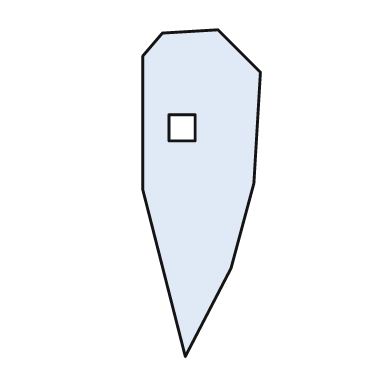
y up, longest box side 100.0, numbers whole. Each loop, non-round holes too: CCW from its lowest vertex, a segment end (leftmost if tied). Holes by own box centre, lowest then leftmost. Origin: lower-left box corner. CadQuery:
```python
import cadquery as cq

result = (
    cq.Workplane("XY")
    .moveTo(13.0, 0.0)
    .lineTo(27.0, 27.0)
    .lineTo(34.0, 53.0)
    .lineTo(36.0, 87.0)
    .lineTo(23.0, 100.0)
    .lineTo(6.0, 99.0)
    .lineTo(0.0, 92.0)
    .lineTo(0.0, 51.0)
    .close()
    .moveTo(8.0, 66.0)
    .lineTo(16.0, 66.0)
    .lineTo(16.0, 74.0)
    .lineTo(8.0, 74.0)
    .close()
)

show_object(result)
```